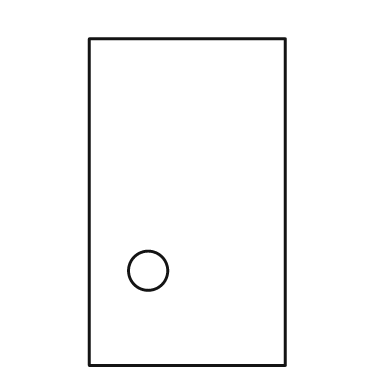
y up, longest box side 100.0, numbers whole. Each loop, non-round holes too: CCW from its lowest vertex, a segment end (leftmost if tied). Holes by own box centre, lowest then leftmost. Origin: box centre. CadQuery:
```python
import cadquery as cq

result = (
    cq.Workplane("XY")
    .moveTo(-30.0, -50.0)
    .lineTo(30.0, -50.0)
    .lineTo(30.0, 50.0)
    .lineTo(-30.0, 50.0)
    .close()
    .moveTo(-12.0, -21.0)
    .circle(6.0)
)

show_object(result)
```